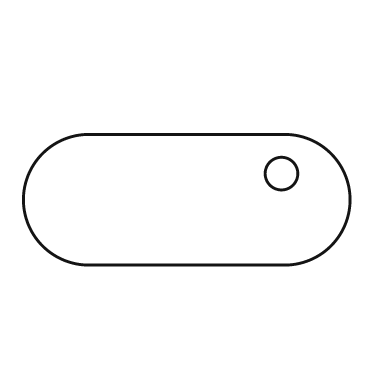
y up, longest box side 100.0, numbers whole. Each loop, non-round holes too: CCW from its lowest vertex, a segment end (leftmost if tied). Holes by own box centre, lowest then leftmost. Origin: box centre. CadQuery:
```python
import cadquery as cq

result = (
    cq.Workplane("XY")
    .moveTo(-30.0, -20.0)
    .lineTo(30.0, -20.0)
    .threePointArc((50.0, 0.0), (30.0, 20.0))
    .lineTo(-30.0, 20.0)
    .threePointArc((-50.0, 0.0), (-30.0, -20.0))
    .close()
    .moveTo(29.0, 8.0)
    .circle(5.0)
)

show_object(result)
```